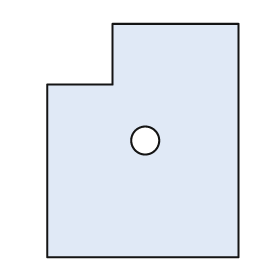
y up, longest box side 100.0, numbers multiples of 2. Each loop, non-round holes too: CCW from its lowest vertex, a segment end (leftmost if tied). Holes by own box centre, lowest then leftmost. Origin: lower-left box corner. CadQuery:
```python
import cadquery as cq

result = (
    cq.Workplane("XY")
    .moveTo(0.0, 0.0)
    .lineTo(82.0, 0.0)
    .lineTo(82.0, 100.0)
    .lineTo(28.0, 100.0)
    .lineTo(28.0, 74.0)
    .lineTo(0.0, 74.0)
    .close()
    .moveTo(42.0, 50.0)
    .circle(6.0)
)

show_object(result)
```